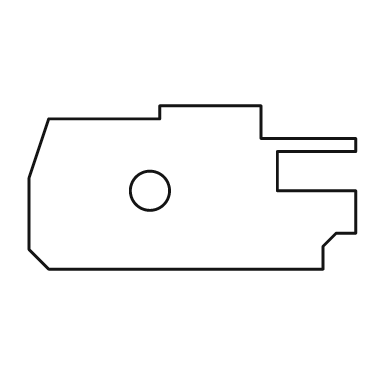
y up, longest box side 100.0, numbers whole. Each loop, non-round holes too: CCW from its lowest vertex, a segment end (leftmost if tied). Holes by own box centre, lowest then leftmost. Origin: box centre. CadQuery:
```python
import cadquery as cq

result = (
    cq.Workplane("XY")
    .moveTo(-44.0, -25.0)
    .lineTo(40.0, -25.0)
    .lineTo(40.0, -18.0)
    .lineTo(44.0, -14.0)
    .lineTo(50.0, -14.0)
    .lineTo(50.0, -1.0)
    .lineTo(26.0, -1.0)
    .lineTo(26.0, 11.0)
    .lineTo(50.0, 11.0)
    .lineTo(50.0, 15.0)
    .lineTo(21.0, 15.0)
    .lineTo(21.0, 25.0)
    .lineTo(-10.0, 25.0)
    .lineTo(-10.0, 21.0)
    .lineTo(-44.0, 21.0)
    .lineTo(-50.0, 3.0)
    .lineTo(-50.0, -19.0)
    .close()
    .moveTo(-13.0, -1.0)
    .circle(6.0)
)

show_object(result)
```